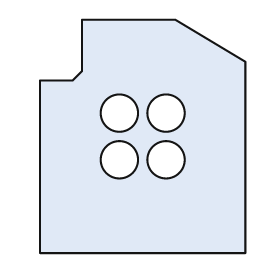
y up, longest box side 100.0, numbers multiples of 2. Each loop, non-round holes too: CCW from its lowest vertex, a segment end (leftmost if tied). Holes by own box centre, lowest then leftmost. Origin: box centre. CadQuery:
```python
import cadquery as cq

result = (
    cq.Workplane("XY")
    .moveTo(-44.0, -50.0)
    .lineTo(44.0, -50.0)
    .lineTo(44.0, 32.0)
    .lineTo(14.0, 50.0)
    .lineTo(-26.0, 50.0)
    .lineTo(-26.0, 28.0)
    .lineTo(-30.0, 24.0)
    .lineTo(-44.0, 24.0)
    .close()
    .moveTo(-10.0, -10.0)
    .circle(8.0)
    .moveTo(10.0, -10.0)
    .circle(8.0)
    .moveTo(-10.0, 10.0)
    .circle(8.0)
    .moveTo(10.0, 10.0)
    .circle(8.0)
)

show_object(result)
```